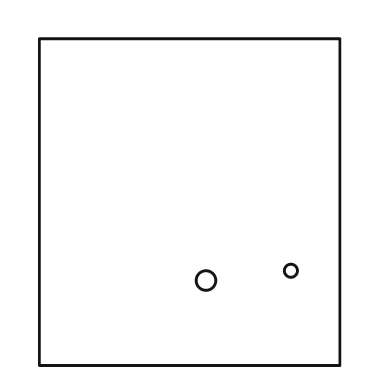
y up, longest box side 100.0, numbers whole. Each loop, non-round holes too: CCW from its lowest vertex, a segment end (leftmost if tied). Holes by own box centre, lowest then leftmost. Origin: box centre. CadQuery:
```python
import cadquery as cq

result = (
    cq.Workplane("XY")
    .moveTo(-46.0, -50.0)
    .lineTo(46.0, -50.0)
    .lineTo(46.0, 50.0)
    .lineTo(-46.0, 50.0)
    .close()
    .moveTo(5.0, -24.0)
    .circle(3.0)
    .moveTo(31.0, -21.0)
    .circle(2.0)
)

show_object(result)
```